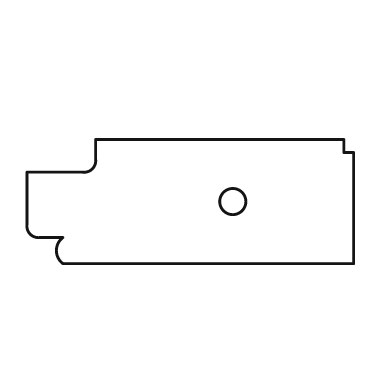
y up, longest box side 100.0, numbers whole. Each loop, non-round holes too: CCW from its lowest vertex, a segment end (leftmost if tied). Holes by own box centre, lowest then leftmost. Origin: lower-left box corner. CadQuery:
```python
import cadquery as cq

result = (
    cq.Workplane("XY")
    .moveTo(11.0, 0.0)
    .lineTo(100.0, 0.0)
    .lineTo(100.0, 34.0)
    .lineTo(97.0, 34.0)
    .lineTo(97.0, 38.0)
    .lineTo(21.0, 38.0)
    .lineTo(21.0, 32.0)
    .threePointArc((20.0, 29.0), (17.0, 28.0))
    .lineTo(0.0, 28.0)
    .lineTo(0.0, 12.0)
    .threePointArc((1.0, 9.0), (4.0, 8.0))
    .lineTo(11.0, 8.0)
    .threePointArc((9.0, 4.0), (11.0, 0.0))
    .close()
    .moveTo(63.0, 19.0)
    .circle(4.0)
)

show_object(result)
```